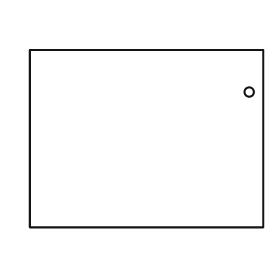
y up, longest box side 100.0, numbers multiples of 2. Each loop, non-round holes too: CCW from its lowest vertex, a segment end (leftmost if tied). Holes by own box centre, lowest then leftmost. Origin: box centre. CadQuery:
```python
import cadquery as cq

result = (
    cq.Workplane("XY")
    .moveTo(-50.0, -38.0)
    .lineTo(50.0, -38.0)
    .lineTo(50.0, 38.0)
    .lineTo(-50.0, 38.0)
    .close()
    .moveTo(44.0, 20.0)
    .circle(2.0)
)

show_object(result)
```